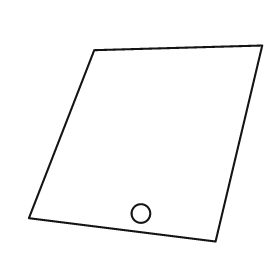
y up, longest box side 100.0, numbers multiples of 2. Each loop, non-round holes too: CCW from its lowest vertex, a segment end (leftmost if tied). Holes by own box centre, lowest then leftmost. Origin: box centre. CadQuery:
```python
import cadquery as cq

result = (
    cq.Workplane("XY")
    .moveTo(30.0, -42.0)
    .lineTo(50.0, 42.0)
    .lineTo(-22.0, 40.0)
    .lineTo(-50.0, -32.0)
    .close()
    .moveTo(-2.0, -30.0)
    .circle(4.0)
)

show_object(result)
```